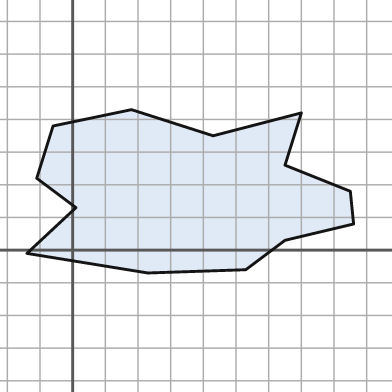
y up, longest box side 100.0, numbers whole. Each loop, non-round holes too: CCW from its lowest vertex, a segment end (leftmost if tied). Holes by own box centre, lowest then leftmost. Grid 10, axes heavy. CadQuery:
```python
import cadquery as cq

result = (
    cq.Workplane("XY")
    .moveTo(23.0, -7.0)
    .lineTo(53.0, -6.0)
    .lineTo(65.0, 3.0)
    .lineTo(86.0, 8.0)
    .lineTo(85.0, 18.0)
    .lineTo(65.0, 26.0)
    .lineTo(70.0, 42.0)
    .lineTo(43.0, 35.0)
    .lineTo(18.0, 43.0)
    .lineTo(-6.0, 38.0)
    .lineTo(-11.0, 22.0)
    .lineTo(1.0, 13.0)
    .lineTo(-14.0, -1.0)
    .close()
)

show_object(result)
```